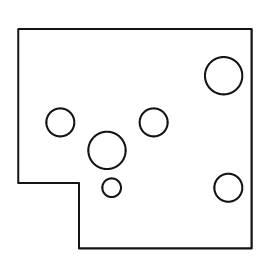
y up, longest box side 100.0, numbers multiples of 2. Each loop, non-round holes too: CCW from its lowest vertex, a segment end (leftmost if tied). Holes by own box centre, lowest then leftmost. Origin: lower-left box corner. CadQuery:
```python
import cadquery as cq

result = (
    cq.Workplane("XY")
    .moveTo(26.0, 0.0)
    .lineTo(100.0, 0.0)
    .lineTo(100.0, 94.0)
    .lineTo(0.0, 94.0)
    .lineTo(0.0, 28.0)
    .lineTo(26.0, 28.0)
    .close()
    .moveTo(40.0, 26.0)
    .circle(4.0)
    .moveTo(90.0, 26.0)
    .circle(6.0)
    .moveTo(38.0, 42.0)
    .circle(8.0)
    .moveTo(18.0, 54.0)
    .circle(6.0)
    .moveTo(58.0, 54.0)
    .circle(6.0)
    .moveTo(88.0, 74.0)
    .circle(8.0)
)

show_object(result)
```